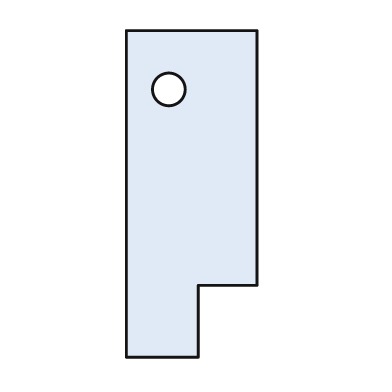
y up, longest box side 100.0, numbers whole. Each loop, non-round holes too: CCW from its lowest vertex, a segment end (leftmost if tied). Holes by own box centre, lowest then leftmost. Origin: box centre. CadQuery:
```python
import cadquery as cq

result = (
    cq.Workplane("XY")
    .moveTo(-20.0, -50.0)
    .lineTo(2.0, -50.0)
    .lineTo(2.0, -28.0)
    .lineTo(20.0, -28.0)
    .lineTo(20.0, 50.0)
    .lineTo(-20.0, 50.0)
    .close()
    .moveTo(-7.0, 32.0)
    .circle(5.0)
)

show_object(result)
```